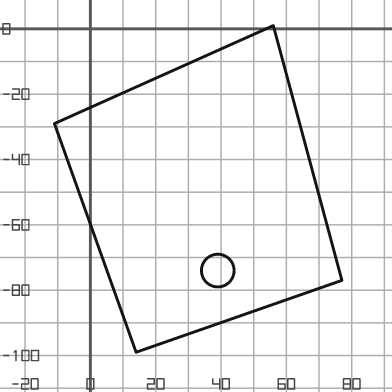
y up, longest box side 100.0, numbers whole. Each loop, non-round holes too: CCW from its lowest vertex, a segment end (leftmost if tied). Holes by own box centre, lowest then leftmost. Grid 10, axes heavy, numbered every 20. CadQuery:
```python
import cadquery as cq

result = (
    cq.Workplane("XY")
    .moveTo(14.0, -99.0)
    .lineTo(77.0, -77.0)
    .lineTo(56.0, 1.0)
    .lineTo(-11.0, -29.0)
    .close()
    .moveTo(39.0, -74.0)
    .circle(5.0)
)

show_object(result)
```